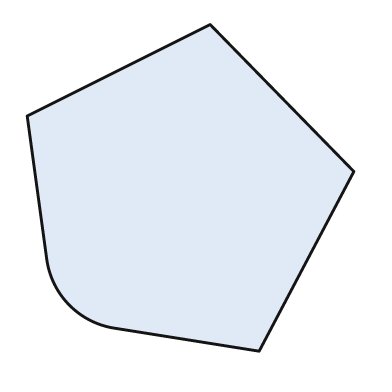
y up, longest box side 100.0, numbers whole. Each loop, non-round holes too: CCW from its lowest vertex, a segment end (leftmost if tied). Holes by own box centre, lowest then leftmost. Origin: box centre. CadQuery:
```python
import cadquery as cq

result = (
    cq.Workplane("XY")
    .moveTo(21.0, -50.0)
    .lineTo(50.0, 5.0)
    .lineTo(6.0, 50.0)
    .lineTo(-50.0, 22.0)
    .lineTo(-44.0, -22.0)
    .threePointArc((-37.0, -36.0), (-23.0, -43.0))
    .close()
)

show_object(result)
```